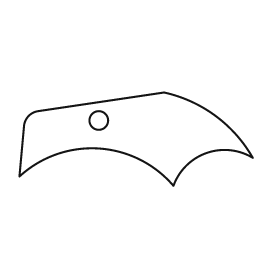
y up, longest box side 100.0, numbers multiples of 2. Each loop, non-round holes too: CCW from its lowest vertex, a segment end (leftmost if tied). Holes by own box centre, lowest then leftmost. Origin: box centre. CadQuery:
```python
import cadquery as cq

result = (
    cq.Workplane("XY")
    .moveTo(16.0, -20.0)
    .threePointArc((30.0, -6.0), (50.0, -8.0))
    .threePointArc((34.0, 10.0), (12.0, 20.0))
    .lineTo(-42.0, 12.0)
    .threePointArc((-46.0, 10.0), (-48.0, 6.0))
    .lineTo(-50.0, -16.0)
    .threePointArc((-16.0, -4.0), (16.0, -20.0))
    .close()
    .moveTo(-16.0, 8.0)
    .circle(4.0)
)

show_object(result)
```